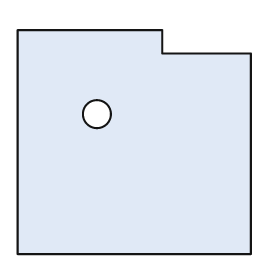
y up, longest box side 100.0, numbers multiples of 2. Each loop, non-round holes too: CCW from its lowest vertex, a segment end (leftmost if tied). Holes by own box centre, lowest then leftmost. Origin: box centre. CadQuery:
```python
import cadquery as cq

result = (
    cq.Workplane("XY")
    .moveTo(-50.0, -48.0)
    .lineTo(50.0, -48.0)
    .lineTo(50.0, 38.0)
    .lineTo(12.0, 38.0)
    .lineTo(12.0, 48.0)
    .lineTo(-50.0, 48.0)
    .close()
    .moveTo(-16.0, 12.0)
    .circle(6.0)
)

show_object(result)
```